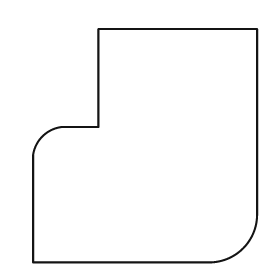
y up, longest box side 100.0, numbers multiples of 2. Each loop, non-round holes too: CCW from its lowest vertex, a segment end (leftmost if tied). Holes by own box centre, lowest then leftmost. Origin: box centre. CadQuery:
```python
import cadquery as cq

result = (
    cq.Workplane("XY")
    .moveTo(-48.0, -50.0)
    .lineTo(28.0, -50.0)
    .threePointArc((42.0, -44.0), (48.0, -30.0))
    .lineTo(48.0, 50.0)
    .lineTo(-20.0, 50.0)
    .lineTo(-20.0, 8.0)
    .lineTo(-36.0, 8.0)
    .threePointArc((-44.0, 4.0), (-48.0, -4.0))
    .close()
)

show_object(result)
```